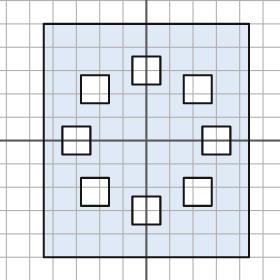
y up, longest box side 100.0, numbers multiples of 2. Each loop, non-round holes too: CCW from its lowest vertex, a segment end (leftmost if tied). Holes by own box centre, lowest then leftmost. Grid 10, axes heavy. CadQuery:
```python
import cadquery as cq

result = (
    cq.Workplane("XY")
    .moveTo(-44.0, -50.0)
    .lineTo(44.0, -50.0)
    .lineTo(44.0, 50.0)
    .lineTo(-44.0, 50.0)
    .close()
    .moveTo(-6.0, -36.0)
    .lineTo(6.0, -36.0)
    .lineTo(6.0, -24.0)
    .lineTo(-6.0, -24.0)
    .close()
    .moveTo(-28.0, -28.0)
    .lineTo(-16.0, -28.0)
    .lineTo(-16.0, -16.0)
    .lineTo(-28.0, -16.0)
    .close()
    .moveTo(16.0, -28.0)
    .lineTo(28.0, -28.0)
    .lineTo(28.0, -16.0)
    .lineTo(16.0, -16.0)
    .close()
    .moveTo(-36.0, -6.0)
    .lineTo(-24.0, -6.0)
    .lineTo(-24.0, 6.0)
    .lineTo(-36.0, 6.0)
    .close()
    .moveTo(24.0, -6.0)
    .lineTo(36.0, -6.0)
    .lineTo(36.0, 6.0)
    .lineTo(24.0, 6.0)
    .close()
    .moveTo(-28.0, 16.0)
    .lineTo(-16.0, 16.0)
    .lineTo(-16.0, 28.0)
    .lineTo(-28.0, 28.0)
    .close()
    .moveTo(16.0, 16.0)
    .lineTo(28.0, 16.0)
    .lineTo(28.0, 28.0)
    .lineTo(16.0, 28.0)
    .close()
    .moveTo(-6.0, 24.0)
    .lineTo(6.0, 24.0)
    .lineTo(6.0, 36.0)
    .lineTo(-6.0, 36.0)
    .close()
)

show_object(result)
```